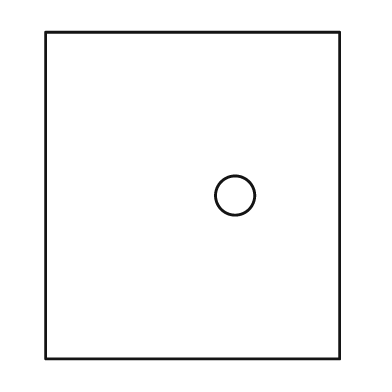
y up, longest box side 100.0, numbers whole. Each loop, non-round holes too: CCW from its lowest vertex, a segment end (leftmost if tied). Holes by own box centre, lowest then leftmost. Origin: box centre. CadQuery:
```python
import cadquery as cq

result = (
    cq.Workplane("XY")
    .moveTo(-45.0, -50.0)
    .lineTo(45.0, -50.0)
    .lineTo(45.0, 50.0)
    .lineTo(-45.0, 50.0)
    .close()
    .moveTo(13.0, 0.0)
    .circle(6.0)
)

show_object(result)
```